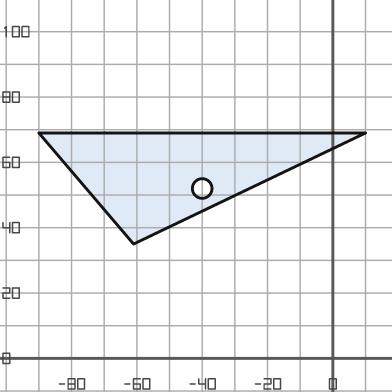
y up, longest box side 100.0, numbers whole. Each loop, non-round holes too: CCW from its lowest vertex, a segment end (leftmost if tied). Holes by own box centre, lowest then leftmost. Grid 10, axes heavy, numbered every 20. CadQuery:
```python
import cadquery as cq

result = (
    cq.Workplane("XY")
    .moveTo(-61.0, 35.0)
    .lineTo(10.0, 69.0)
    .lineTo(-90.0, 69.0)
    .close()
    .moveTo(-40.0, 52.0)
    .circle(3.0)
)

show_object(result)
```